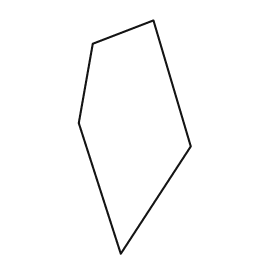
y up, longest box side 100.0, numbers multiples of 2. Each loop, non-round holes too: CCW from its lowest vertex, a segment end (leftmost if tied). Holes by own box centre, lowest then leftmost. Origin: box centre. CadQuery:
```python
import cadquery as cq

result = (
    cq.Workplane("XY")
    .moveTo(-6.0, -50.0)
    .lineTo(24.0, -4.0)
    .lineTo(8.0, 50.0)
    .lineTo(-18.0, 40.0)
    .lineTo(-24.0, 6.0)
    .close()
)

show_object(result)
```